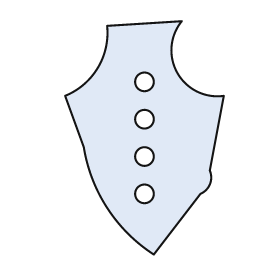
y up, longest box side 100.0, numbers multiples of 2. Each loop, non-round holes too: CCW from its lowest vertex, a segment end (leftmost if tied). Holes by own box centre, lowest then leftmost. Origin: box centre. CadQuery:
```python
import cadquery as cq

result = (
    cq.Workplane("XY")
    .moveTo(4.0, -50.0)
    .lineTo(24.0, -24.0)
    .threePointArc((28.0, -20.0), (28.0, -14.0))
    .lineTo(34.0, 18.0)
    .threePointArc((14.0, 28.0), (16.0, 50.0))
    .lineTo(-16.0, 48.0)
    .threePointArc((-20.0, 30.0), (-34.0, 18.0))
    .lineTo(-26.0, -4.0)
    .threePointArc((-16.0, -30.0), (4.0, -50.0))
    .close()
    .moveTo(0.0, -24.0)
    .circle(4.0)
    .moveTo(0.0, -8.0)
    .circle(4.0)
    .moveTo(0.0, 8.0)
    .circle(4.0)
    .moveTo(0.0, 24.0)
    .circle(4.0)
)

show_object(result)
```